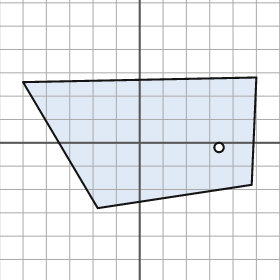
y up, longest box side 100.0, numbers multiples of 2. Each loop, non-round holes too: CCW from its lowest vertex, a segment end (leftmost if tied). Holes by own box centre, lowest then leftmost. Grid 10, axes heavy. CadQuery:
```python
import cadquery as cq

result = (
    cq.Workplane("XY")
    .moveTo(-18.0, -28.0)
    .lineTo(48.0, -18.0)
    .lineTo(50.0, 28.0)
    .lineTo(-50.0, 26.0)
    .close()
    .moveTo(34.0, -2.0)
    .circle(2.0)
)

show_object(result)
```